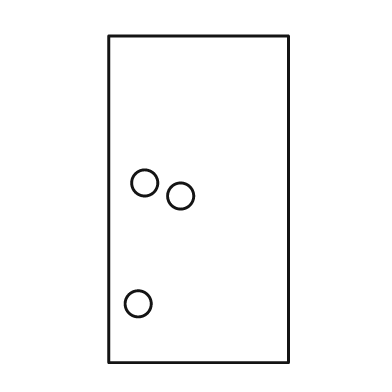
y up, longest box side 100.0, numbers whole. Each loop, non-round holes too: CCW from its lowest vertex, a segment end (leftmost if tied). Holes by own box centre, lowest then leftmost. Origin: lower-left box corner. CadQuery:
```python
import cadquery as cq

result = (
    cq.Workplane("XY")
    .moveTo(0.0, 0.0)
    .lineTo(55.0, 0.0)
    .lineTo(55.0, 100.0)
    .lineTo(0.0, 100.0)
    .close()
    .moveTo(9.0, 18.0)
    .circle(4.0)
    .moveTo(22.0, 51.0)
    .circle(4.0)
    .moveTo(11.0, 55.0)
    .circle(4.0)
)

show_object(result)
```